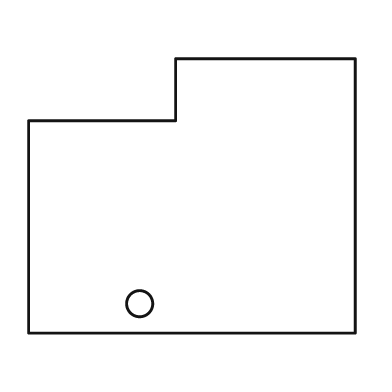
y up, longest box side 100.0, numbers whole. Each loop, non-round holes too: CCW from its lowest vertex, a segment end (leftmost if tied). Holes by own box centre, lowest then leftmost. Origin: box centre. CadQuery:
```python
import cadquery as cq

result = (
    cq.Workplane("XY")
    .moveTo(-50.0, -42.0)
    .lineTo(50.0, -42.0)
    .lineTo(50.0, 42.0)
    .lineTo(-5.0, 42.0)
    .lineTo(-5.0, 23.0)
    .lineTo(-50.0, 23.0)
    .close()
    .moveTo(-16.0, -33.0)
    .circle(4.0)
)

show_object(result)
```